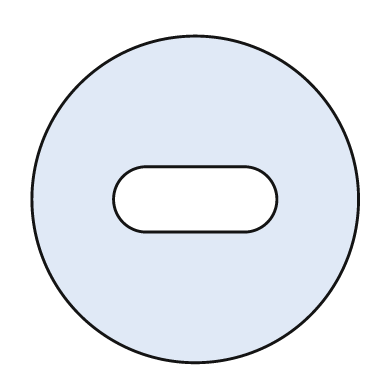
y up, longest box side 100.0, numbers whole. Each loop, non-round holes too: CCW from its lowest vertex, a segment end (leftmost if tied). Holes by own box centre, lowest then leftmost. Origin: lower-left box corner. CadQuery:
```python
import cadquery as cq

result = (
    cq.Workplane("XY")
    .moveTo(50.0, 50.0)
    .circle(50.0)
    .moveTo(35.0, 40.0)
    .lineTo(65.0, 40.0)
    .threePointArc((75.0, 50.0), (65.0, 60.0))
    .lineTo(35.0, 60.0)
    .threePointArc((25.0, 50.0), (35.0, 40.0))
    .close()
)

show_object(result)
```